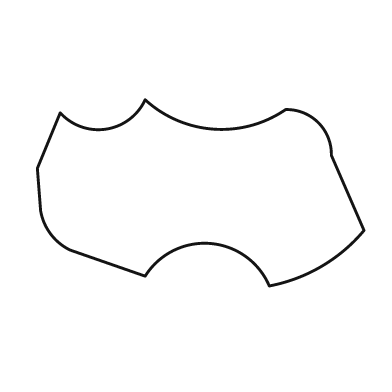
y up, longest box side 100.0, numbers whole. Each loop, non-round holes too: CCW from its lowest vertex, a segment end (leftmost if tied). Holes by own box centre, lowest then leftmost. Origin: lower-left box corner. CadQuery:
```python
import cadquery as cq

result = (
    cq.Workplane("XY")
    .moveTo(71.0, 0.0)
    .threePointArc((87.0, 6.0), (100.0, 17.0))
    .lineTo(90.0, 40.0)
    .threePointArc((86.0, 50.0), (76.0, 54.0))
    .threePointArc((54.0, 48.0), (33.0, 57.0))
    .threePointArc((21.0, 48.0), (7.0, 53.0))
    .lineTo(0.0, 36.0)
    .lineTo(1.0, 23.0)
    .threePointArc((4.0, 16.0), (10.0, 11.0))
    .lineTo(33.0, 3.0)
    .threePointArc((53.0, 13.0), (71.0, 0.0))
    .close()
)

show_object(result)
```